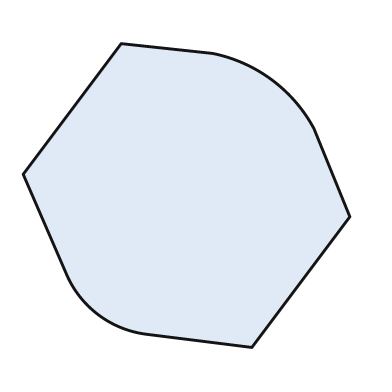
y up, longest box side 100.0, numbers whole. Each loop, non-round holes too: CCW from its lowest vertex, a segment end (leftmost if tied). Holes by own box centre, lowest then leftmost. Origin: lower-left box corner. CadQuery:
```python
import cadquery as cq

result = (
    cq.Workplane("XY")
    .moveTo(70.0, 0.0)
    .lineTo(100.0, 40.0)
    .lineTo(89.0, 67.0)
    .threePointArc((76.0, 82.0), (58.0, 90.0))
    .lineTo(30.0, 93.0)
    .lineTo(0.0, 53.0)
    .lineTo(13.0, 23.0)
    .threePointArc((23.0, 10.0), (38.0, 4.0))
    .close()
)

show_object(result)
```